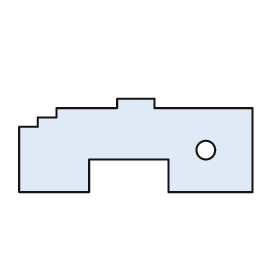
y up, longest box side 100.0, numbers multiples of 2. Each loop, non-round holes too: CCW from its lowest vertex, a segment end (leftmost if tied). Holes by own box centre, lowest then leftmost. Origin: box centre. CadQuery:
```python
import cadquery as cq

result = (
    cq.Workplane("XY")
    .moveTo(-50.0, -20.0)
    .lineTo(-20.0, -20.0)
    .lineTo(-20.0, -6.0)
    .lineTo(14.0, -6.0)
    .lineTo(14.0, -20.0)
    .lineTo(50.0, -20.0)
    .lineTo(50.0, 16.0)
    .lineTo(8.0, 16.0)
    .lineTo(8.0, 20.0)
    .lineTo(-8.0, 20.0)
    .lineTo(-8.0, 16.0)
    .lineTo(-34.0, 16.0)
    .lineTo(-34.0, 12.0)
    .lineTo(-42.0, 12.0)
    .lineTo(-42.0, 8.0)
    .lineTo(-50.0, 8.0)
    .close()
    .moveTo(30.0, -2.0)
    .circle(4.0)
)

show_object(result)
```